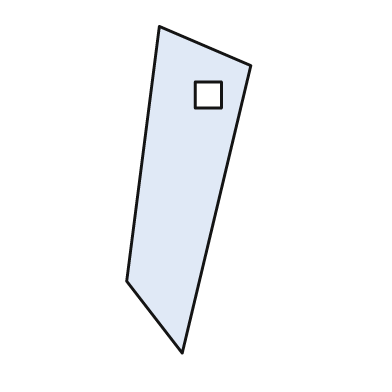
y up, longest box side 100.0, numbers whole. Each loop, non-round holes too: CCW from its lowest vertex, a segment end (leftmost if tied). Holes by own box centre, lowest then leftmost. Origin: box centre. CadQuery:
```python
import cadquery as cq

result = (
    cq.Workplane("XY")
    .moveTo(-2.0, -50.0)
    .lineTo(19.0, 38.0)
    .lineTo(-9.0, 50.0)
    .lineTo(-19.0, -28.0)
    .close()
    .moveTo(2.0, 25.0)
    .lineTo(10.0, 25.0)
    .lineTo(10.0, 33.0)
    .lineTo(2.0, 33.0)
    .close()
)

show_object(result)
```